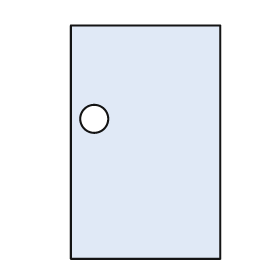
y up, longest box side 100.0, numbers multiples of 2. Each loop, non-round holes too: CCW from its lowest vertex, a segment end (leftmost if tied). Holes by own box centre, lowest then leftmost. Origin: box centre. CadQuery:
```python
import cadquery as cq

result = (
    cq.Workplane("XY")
    .moveTo(-32.0, -50.0)
    .lineTo(32.0, -50.0)
    .lineTo(32.0, 50.0)
    .lineTo(-32.0, 50.0)
    .close()
    .moveTo(-22.0, 10.0)
    .circle(6.0)
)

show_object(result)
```